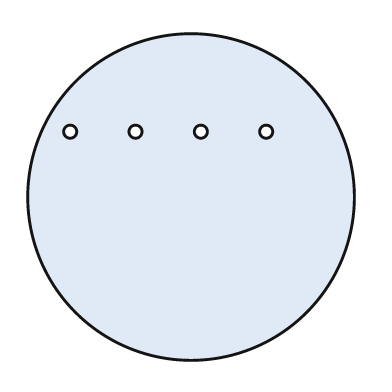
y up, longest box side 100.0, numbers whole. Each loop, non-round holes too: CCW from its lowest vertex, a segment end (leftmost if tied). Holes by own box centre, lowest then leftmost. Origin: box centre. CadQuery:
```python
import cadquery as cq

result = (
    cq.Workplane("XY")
    .moveTo(0.0, 0.0)
    .circle(50.0)
    .moveTo(-37.0, 20.0)
    .circle(2.0)
    .moveTo(-17.0, 20.0)
    .circle(2.0)
    .moveTo(3.0, 20.0)
    .circle(2.0)
    .moveTo(23.0, 20.0)
    .circle(2.0)
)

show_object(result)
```